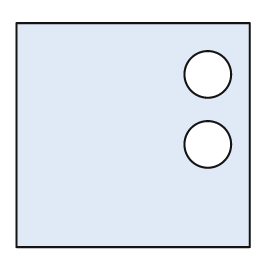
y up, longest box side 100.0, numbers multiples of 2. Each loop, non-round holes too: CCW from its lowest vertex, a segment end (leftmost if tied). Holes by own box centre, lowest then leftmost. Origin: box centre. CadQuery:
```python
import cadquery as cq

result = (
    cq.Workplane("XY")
    .moveTo(-50.0, -48.0)
    .lineTo(50.0, -48.0)
    .lineTo(50.0, 48.0)
    .lineTo(-50.0, 48.0)
    .close()
    .moveTo(32.0, -4.0)
    .circle(10.0)
    .moveTo(32.0, 26.0)
    .circle(10.0)
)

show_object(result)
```